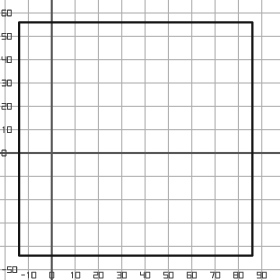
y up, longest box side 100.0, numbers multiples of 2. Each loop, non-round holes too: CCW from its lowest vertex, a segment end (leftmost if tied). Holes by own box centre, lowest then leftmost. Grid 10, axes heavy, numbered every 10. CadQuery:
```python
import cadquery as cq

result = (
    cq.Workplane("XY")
    .moveTo(-14.0, -44.0)
    .lineTo(86.0, -44.0)
    .lineTo(86.0, 56.0)
    .lineTo(-14.0, 56.0)
    .close()
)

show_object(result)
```